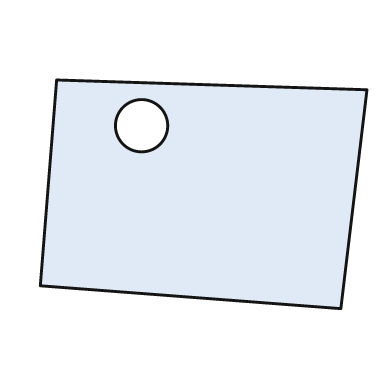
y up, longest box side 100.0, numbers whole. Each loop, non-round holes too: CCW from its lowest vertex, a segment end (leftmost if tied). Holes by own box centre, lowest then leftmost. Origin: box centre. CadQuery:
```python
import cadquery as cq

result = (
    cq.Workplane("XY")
    .moveTo(42.0, -35.0)
    .lineTo(50.0, 32.0)
    .lineTo(-45.0, 35.0)
    .lineTo(-50.0, -28.0)
    .close()
    .moveTo(-19.0, 21.0)
    .circle(8.0)
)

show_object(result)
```